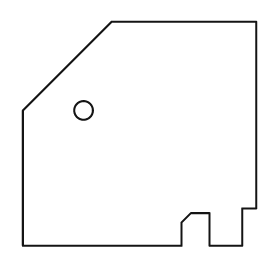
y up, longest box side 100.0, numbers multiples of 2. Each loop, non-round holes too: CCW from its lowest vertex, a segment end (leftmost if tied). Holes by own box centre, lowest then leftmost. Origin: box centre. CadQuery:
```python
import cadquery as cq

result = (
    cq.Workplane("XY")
    .moveTo(-50.0, -48.0)
    .lineTo(18.0, -48.0)
    .lineTo(18.0, -38.0)
    .lineTo(22.0, -34.0)
    .lineTo(30.0, -34.0)
    .lineTo(30.0, -48.0)
    .lineTo(44.0, -48.0)
    .lineTo(44.0, -32.0)
    .lineTo(50.0, -32.0)
    .lineTo(50.0, 48.0)
    .lineTo(-12.0, 48.0)
    .lineTo(-50.0, 10.0)
    .close()
    .moveTo(-24.0, 10.0)
    .circle(4.0)
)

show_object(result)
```